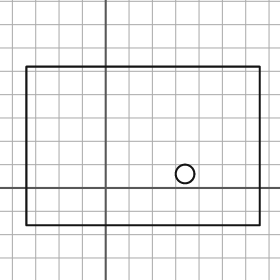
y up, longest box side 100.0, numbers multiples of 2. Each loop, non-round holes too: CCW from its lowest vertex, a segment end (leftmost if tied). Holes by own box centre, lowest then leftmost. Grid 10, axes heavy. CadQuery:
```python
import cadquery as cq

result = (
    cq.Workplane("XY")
    .moveTo(-34.0, -16.0)
    .lineTo(66.0, -16.0)
    .lineTo(66.0, 52.0)
    .lineTo(-34.0, 52.0)
    .close()
    .moveTo(34.0, 6.0)
    .circle(4.0)
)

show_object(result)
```